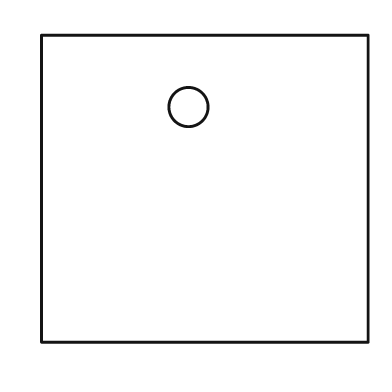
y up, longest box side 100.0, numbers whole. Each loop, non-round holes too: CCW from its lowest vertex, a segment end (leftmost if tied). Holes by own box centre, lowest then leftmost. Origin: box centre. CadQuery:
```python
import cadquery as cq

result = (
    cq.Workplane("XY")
    .moveTo(-50.0, -47.0)
    .lineTo(50.0, -47.0)
    .lineTo(50.0, 47.0)
    .lineTo(-50.0, 47.0)
    .close()
    .moveTo(-5.0, 25.0)
    .circle(6.0)
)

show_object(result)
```